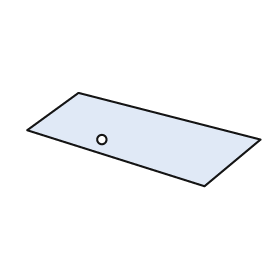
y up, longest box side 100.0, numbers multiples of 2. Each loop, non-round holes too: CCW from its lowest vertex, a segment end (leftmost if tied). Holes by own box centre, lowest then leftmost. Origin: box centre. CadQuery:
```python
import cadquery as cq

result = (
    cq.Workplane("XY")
    .moveTo(26.0, -20.0)
    .lineTo(50.0, 0.0)
    .lineTo(-28.0, 20.0)
    .lineTo(-50.0, 4.0)
    .close()
    .moveTo(-18.0, 0.0)
    .circle(2.0)
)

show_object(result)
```